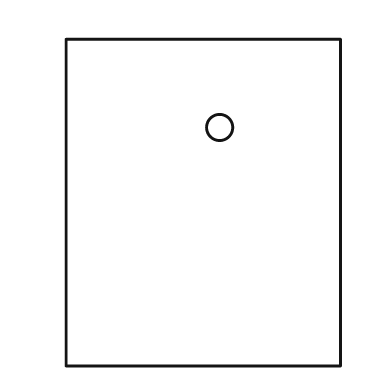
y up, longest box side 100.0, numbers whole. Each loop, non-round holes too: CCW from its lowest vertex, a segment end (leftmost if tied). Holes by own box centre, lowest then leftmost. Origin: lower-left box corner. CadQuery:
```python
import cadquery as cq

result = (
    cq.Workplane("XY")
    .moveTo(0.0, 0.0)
    .lineTo(84.0, 0.0)
    .lineTo(84.0, 100.0)
    .lineTo(0.0, 100.0)
    .close()
    .moveTo(47.0, 73.0)
    .circle(4.0)
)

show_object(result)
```